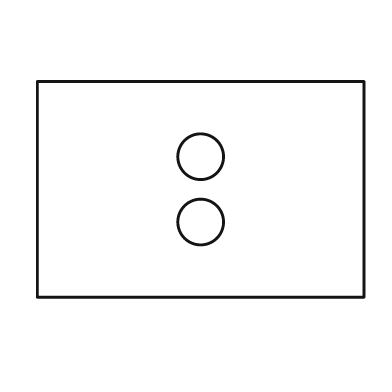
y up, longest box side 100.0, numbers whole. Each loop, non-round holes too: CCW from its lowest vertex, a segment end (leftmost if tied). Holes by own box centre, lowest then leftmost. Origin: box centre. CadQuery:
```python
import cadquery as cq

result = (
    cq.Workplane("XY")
    .moveTo(-50.0, -33.0)
    .lineTo(50.0, -33.0)
    .lineTo(50.0, 33.0)
    .lineTo(-50.0, 33.0)
    .close()
    .moveTo(0.0, -10.0)
    .circle(7.0)
    .moveTo(0.0, 10.0)
    .circle(7.0)
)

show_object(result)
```